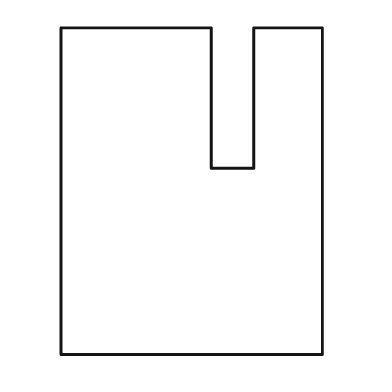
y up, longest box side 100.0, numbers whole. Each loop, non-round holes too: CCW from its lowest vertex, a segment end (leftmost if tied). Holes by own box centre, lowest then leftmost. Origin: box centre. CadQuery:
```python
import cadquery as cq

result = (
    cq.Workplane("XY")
    .moveTo(-40.0, -50.0)
    .lineTo(40.0, -50.0)
    .lineTo(40.0, 50.0)
    .lineTo(19.0, 50.0)
    .lineTo(19.0, 7.0)
    .lineTo(6.0, 7.0)
    .lineTo(6.0, 50.0)
    .lineTo(-40.0, 50.0)
    .close()
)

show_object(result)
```